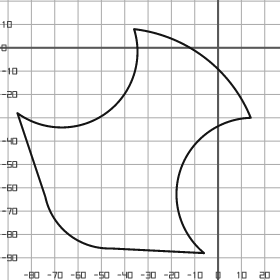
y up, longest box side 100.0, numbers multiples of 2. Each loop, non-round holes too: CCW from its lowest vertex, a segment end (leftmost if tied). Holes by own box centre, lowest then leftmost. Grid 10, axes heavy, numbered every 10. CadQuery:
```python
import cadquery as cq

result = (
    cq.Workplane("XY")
    .moveTo(-6.0, -88.0)
    .threePointArc((-16.0, -52.0), (14.0, -30.0))
    .threePointArc((-6.0, -4.0), (-36.0, 8.0))
    .threePointArc((-48.0, -28.0), (-86.0, -28.0))
    .lineTo(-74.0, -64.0)
    .threePointArc((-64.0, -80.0), (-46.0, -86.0))
    .close()
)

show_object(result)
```